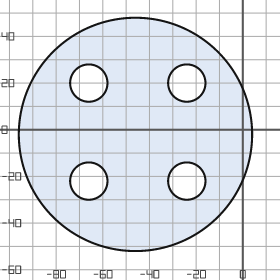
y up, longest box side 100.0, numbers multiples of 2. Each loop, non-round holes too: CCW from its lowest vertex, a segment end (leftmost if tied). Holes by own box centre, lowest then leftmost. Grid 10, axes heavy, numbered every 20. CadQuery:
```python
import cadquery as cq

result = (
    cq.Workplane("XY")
    .moveTo(-46.0, -2.0)
    .circle(50.0)
    .moveTo(-66.0, -22.0)
    .circle(8.0)
    .moveTo(-24.0, -22.0)
    .circle(8.0)
    .moveTo(-66.0, 20.0)
    .circle(8.0)
    .moveTo(-24.0, 20.0)
    .circle(8.0)
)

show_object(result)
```